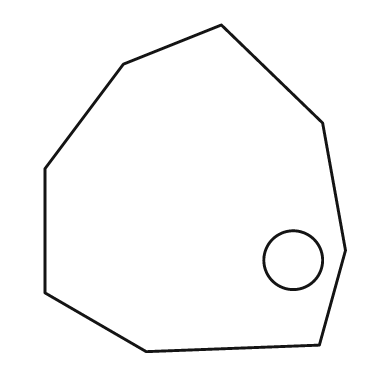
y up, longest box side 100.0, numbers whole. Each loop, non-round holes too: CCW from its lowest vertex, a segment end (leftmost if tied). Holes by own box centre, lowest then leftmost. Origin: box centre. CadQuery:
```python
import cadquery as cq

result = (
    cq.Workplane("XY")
    .moveTo(-15.0, -50.0)
    .lineTo(38.0, -48.0)
    .lineTo(46.0, -19.0)
    .lineTo(39.0, 20.0)
    .lineTo(8.0, 50.0)
    .lineTo(-22.0, 38.0)
    .lineTo(-46.0, 6.0)
    .lineTo(-46.0, -32.0)
    .close()
    .moveTo(30.0, -22.0)
    .circle(9.0)
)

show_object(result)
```